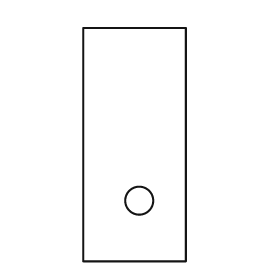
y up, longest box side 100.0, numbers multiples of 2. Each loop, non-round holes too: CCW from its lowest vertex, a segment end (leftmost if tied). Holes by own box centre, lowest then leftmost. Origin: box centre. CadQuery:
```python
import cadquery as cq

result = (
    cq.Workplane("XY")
    .moveTo(-22.0, -50.0)
    .lineTo(22.0, -50.0)
    .lineTo(22.0, 50.0)
    .lineTo(-22.0, 50.0)
    .close()
    .moveTo(2.0, -24.0)
    .circle(6.0)
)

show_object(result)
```